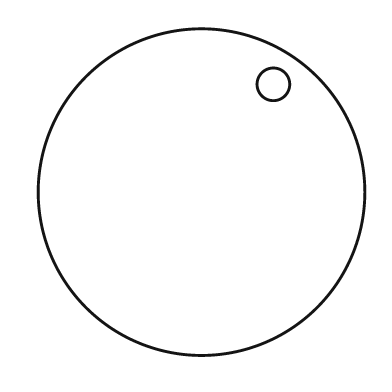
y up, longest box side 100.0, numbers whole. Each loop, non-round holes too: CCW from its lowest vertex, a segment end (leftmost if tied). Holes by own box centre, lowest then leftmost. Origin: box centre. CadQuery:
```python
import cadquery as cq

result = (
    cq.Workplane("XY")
    .moveTo(0.0, 0.0)
    .circle(50.0)
    .moveTo(22.0, 33.0)
    .circle(5.0)
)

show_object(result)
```